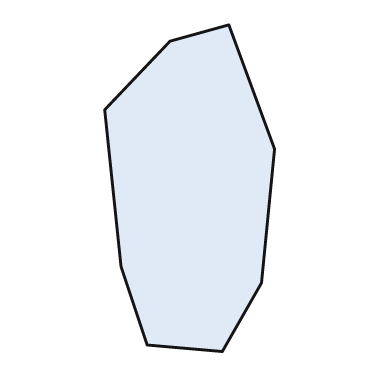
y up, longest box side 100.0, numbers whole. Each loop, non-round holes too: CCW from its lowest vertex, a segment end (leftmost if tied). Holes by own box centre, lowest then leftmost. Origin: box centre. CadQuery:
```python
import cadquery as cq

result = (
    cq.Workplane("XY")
    .moveTo(10.0, -50.0)
    .lineTo(22.0, -29.0)
    .lineTo(26.0, 12.0)
    .lineTo(12.0, 50.0)
    .lineTo(-6.0, 45.0)
    .lineTo(-26.0, 24.0)
    .lineTo(-21.0, -24.0)
    .lineTo(-13.0, -48.0)
    .close()
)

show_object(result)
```